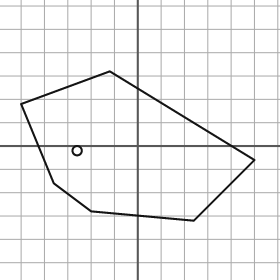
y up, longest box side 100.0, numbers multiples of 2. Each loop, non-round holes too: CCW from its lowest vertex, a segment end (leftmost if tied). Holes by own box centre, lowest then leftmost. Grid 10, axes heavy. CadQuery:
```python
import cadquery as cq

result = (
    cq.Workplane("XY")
    .moveTo(24.0, -32.0)
    .lineTo(50.0, -6.0)
    .lineTo(-12.0, 32.0)
    .lineTo(-50.0, 18.0)
    .lineTo(-36.0, -16.0)
    .lineTo(-20.0, -28.0)
    .close()
    .moveTo(-26.0, -2.0)
    .circle(2.0)
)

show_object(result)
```